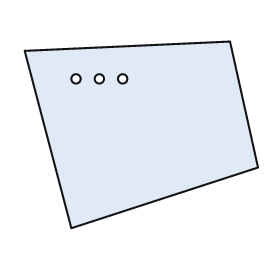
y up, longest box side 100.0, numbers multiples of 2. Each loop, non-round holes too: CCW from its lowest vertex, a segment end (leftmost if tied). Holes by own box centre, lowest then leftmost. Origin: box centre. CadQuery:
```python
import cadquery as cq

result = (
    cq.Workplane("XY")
    .moveTo(-30.0, -40.0)
    .lineTo(50.0, -14.0)
    .lineTo(38.0, 40.0)
    .lineTo(-50.0, 36.0)
    .close()
    .moveTo(-28.0, 24.0)
    .circle(2.0)
    .moveTo(-18.0, 24.0)
    .circle(2.0)
    .moveTo(-8.0, 24.0)
    .circle(2.0)
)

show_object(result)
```